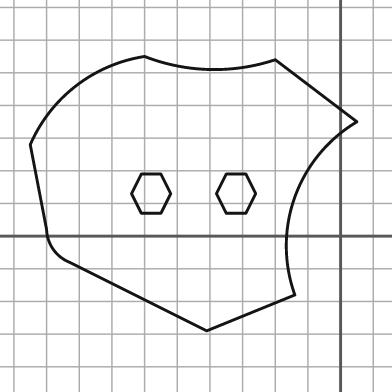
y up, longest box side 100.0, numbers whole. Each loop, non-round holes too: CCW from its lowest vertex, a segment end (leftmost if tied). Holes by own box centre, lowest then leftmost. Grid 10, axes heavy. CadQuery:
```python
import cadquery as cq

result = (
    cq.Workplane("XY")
    .moveTo(-41.0, -29.0)
    .lineTo(-14.0, -18.0)
    .threePointArc((-14.0, 12.0), (5.0, 35.0))
    .lineTo(-20.0, 54.0)
    .threePointArc((-40.0, 51.0), (-60.0, 55.0))
    .threePointArc((-81.0, 46.0), (-95.0, 28.0))
    .lineTo(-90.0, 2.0)
    .threePointArc((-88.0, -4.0), (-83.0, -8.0))
    .close()
    .moveTo(-61.0, 7.0)
    .lineTo(-55.0, 7.0)
    .lineTo(-52.0, 13.0)
    .lineTo(-55.0, 19.0)
    .lineTo(-61.0, 19.0)
    .lineTo(-64.0, 13.0)
    .close()
    .moveTo(-35.0, 7.0)
    .lineTo(-29.0, 7.0)
    .lineTo(-26.0, 13.0)
    .lineTo(-29.0, 19.0)
    .lineTo(-35.0, 19.0)
    .lineTo(-38.0, 13.0)
    .close()
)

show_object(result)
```